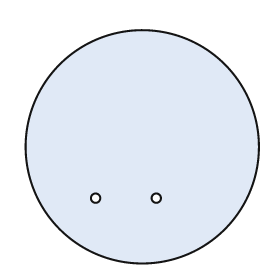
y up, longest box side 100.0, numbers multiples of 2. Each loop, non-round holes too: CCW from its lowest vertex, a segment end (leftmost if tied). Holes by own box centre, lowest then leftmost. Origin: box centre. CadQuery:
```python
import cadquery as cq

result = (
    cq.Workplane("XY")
    .moveTo(0.0, 0.0)
    .circle(50.0)
    .moveTo(-20.0, -22.0)
    .circle(2.0)
    .moveTo(6.0, -22.0)
    .circle(2.0)
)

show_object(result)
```